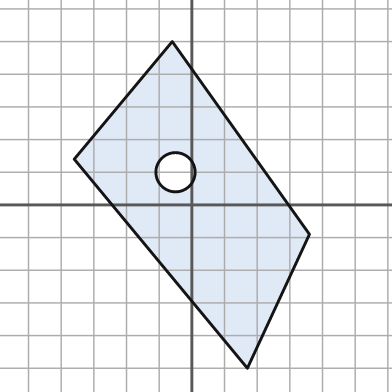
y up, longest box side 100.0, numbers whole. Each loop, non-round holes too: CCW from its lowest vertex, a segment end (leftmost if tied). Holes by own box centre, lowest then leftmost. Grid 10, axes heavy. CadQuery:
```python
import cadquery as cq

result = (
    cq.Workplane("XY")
    .moveTo(17.0, -50.0)
    .lineTo(36.0, -9.0)
    .lineTo(-6.0, 50.0)
    .lineTo(-36.0, 14.0)
    .close()
    .moveTo(-5.0, 10.0)
    .circle(6.0)
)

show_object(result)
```